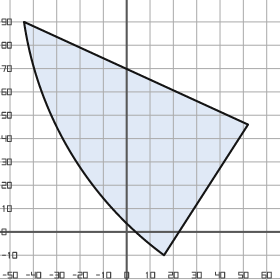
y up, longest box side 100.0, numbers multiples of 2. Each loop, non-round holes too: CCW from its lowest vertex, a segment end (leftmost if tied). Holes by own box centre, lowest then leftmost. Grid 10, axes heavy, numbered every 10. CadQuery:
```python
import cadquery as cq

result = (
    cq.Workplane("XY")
    .moveTo(16.0, -10.0)
    .lineTo(52.0, 46.0)
    .lineTo(-44.0, 90.0)
    .threePointArc((-24.0, 34.0), (16.0, -10.0))
    .close()
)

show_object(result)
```